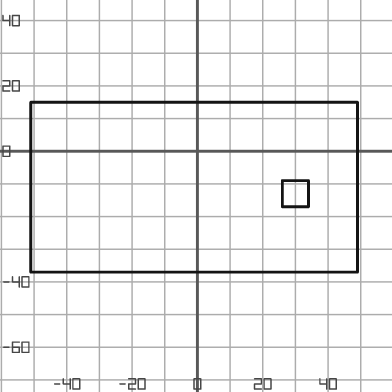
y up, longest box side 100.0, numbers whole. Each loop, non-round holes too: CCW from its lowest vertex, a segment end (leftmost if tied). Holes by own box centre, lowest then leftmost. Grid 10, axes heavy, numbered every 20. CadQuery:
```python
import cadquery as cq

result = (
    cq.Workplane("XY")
    .moveTo(-51.0, -37.0)
    .lineTo(49.0, -37.0)
    .lineTo(49.0, 15.0)
    .lineTo(-51.0, 15.0)
    .close()
    .moveTo(26.0, -17.0)
    .lineTo(34.0, -17.0)
    .lineTo(34.0, -9.0)
    .lineTo(26.0, -9.0)
    .close()
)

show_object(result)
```